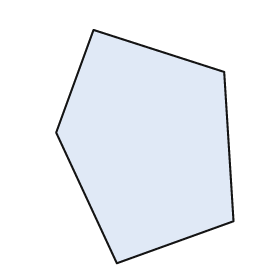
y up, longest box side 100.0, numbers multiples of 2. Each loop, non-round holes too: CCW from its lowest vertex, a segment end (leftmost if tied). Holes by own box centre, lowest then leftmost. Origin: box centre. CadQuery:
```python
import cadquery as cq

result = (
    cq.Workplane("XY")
    .moveTo(-12.0, -50.0)
    .lineTo(38.0, -32.0)
    .lineTo(34.0, 32.0)
    .lineTo(-22.0, 50.0)
    .lineTo(-38.0, 6.0)
    .close()
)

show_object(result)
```